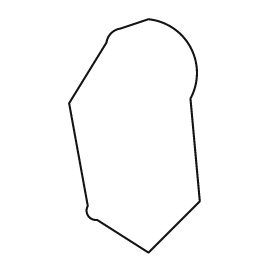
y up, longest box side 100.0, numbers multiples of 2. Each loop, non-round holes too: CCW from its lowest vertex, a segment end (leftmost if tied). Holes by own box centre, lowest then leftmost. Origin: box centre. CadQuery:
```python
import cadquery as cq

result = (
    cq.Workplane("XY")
    .moveTo(6.0, -50.0)
    .lineTo(28.0, -28.0)
    .lineTo(24.0, 16.0)
    .threePointArc((24.0, 38.0), (6.0, 50.0))
    .lineTo(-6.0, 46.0)
    .threePointArc((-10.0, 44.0), (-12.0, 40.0))
    .lineTo(-28.0, 14.0)
    .lineTo(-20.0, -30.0)
    .threePointArc((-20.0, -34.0), (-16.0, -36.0))
    .close()
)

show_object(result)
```